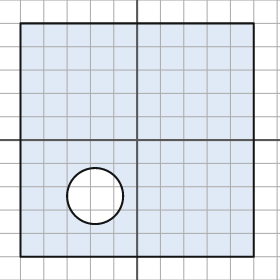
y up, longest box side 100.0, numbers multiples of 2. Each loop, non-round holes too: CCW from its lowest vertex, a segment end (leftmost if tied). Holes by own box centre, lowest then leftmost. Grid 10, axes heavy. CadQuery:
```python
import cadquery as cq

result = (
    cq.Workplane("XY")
    .moveTo(-50.0, -50.0)
    .lineTo(50.0, -50.0)
    .lineTo(50.0, 50.0)
    .lineTo(-50.0, 50.0)
    .close()
    .moveTo(-18.0, -24.0)
    .circle(12.0)
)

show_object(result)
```